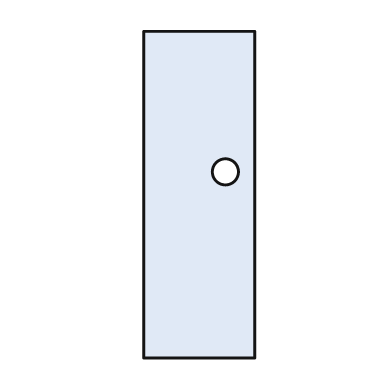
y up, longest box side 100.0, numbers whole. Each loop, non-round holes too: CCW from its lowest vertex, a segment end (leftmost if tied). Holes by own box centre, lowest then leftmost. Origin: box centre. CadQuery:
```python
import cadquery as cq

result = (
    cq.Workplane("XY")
    .moveTo(-17.0, -50.0)
    .lineTo(17.0, -50.0)
    .lineTo(17.0, 50.0)
    .lineTo(-17.0, 50.0)
    .close()
    .moveTo(8.0, 7.0)
    .circle(4.0)
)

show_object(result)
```